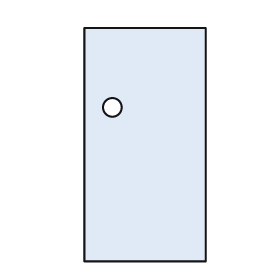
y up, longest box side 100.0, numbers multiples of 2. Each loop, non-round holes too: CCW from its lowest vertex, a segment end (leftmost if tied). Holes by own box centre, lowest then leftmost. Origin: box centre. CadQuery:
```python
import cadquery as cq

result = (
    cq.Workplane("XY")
    .moveTo(-26.0, -50.0)
    .lineTo(26.0, -50.0)
    .lineTo(26.0, 50.0)
    .lineTo(-26.0, 50.0)
    .close()
    .moveTo(-14.0, 16.0)
    .circle(4.0)
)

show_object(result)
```